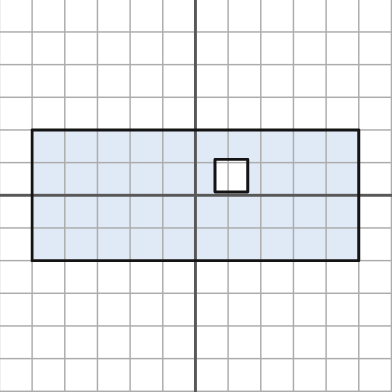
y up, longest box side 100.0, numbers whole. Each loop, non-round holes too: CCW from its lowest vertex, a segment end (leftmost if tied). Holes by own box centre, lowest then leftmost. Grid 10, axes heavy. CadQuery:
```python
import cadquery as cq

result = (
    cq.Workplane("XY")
    .moveTo(-50.0, -20.0)
    .lineTo(50.0, -20.0)
    .lineTo(50.0, 20.0)
    .lineTo(-50.0, 20.0)
    .close()
    .moveTo(6.0, 1.0)
    .lineTo(16.0, 1.0)
    .lineTo(16.0, 11.0)
    .lineTo(6.0, 11.0)
    .close()
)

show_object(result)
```